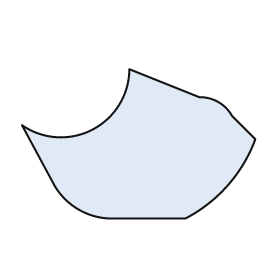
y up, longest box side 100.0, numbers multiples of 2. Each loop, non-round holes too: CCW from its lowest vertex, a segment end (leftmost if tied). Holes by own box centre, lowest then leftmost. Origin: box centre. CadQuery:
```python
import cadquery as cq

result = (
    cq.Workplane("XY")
    .moveTo(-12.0, -32.0)
    .lineTo(20.0, -32.0)
    .threePointArc((38.0, -18.0), (50.0, 2.0))
    .lineTo(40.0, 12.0)
    .threePointArc((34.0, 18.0), (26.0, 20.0))
    .lineTo(-4.0, 32.0)
    .threePointArc((-20.0, 6.0), (-50.0, 8.0))
    .lineTo(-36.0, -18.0)
    .threePointArc((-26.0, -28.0), (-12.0, -32.0))
    .close()
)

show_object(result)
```